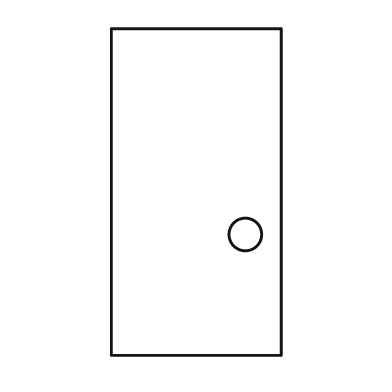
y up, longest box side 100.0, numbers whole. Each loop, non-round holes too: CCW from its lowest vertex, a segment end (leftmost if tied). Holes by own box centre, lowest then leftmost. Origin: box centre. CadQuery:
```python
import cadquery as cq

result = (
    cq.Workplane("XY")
    .moveTo(-26.0, -50.0)
    .lineTo(26.0, -50.0)
    .lineTo(26.0, 50.0)
    .lineTo(-26.0, 50.0)
    .close()
    .moveTo(15.0, -13.0)
    .circle(5.0)
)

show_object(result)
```